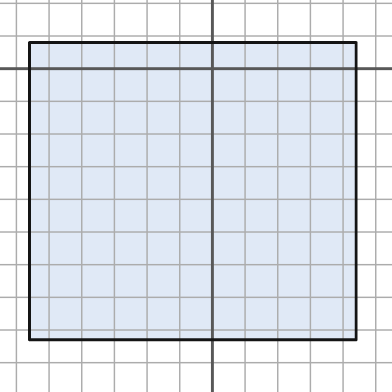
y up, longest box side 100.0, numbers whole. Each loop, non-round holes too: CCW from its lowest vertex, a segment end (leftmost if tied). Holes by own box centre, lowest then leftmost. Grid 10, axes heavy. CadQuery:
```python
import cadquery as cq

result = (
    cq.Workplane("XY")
    .moveTo(-56.0, -83.0)
    .lineTo(44.0, -83.0)
    .lineTo(44.0, 8.0)
    .lineTo(-56.0, 8.0)
    .close()
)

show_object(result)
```